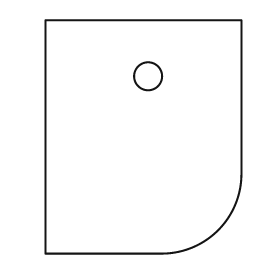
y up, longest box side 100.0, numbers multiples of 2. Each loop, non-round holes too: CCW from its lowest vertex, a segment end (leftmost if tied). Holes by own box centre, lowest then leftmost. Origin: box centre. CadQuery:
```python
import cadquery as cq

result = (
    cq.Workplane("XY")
    .moveTo(-42.0, -50.0)
    .lineTo(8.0, -50.0)
    .threePointArc((32.0, -40.0), (42.0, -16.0))
    .lineTo(42.0, 50.0)
    .lineTo(-42.0, 50.0)
    .close()
    .moveTo(2.0, 26.0)
    .circle(6.0)
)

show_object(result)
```